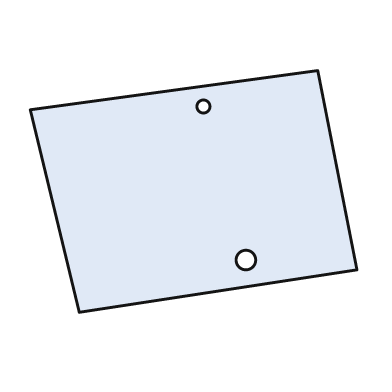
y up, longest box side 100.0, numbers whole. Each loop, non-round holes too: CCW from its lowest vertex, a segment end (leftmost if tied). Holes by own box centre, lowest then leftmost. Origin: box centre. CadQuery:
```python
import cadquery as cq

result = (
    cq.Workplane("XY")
    .moveTo(-35.0, -37.0)
    .lineTo(50.0, -24.0)
    .lineTo(38.0, 37.0)
    .lineTo(-50.0, 25.0)
    .close()
    .moveTo(16.0, -21.0)
    .circle(3.0)
    .moveTo(3.0, 26.0)
    .circle(2.0)
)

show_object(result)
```